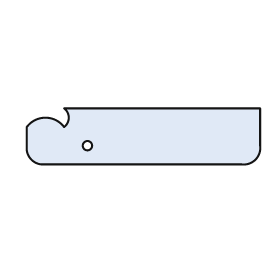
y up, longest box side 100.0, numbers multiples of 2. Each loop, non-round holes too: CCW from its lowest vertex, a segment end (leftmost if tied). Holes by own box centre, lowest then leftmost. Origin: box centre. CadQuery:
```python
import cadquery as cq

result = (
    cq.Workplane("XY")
    .moveTo(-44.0, -12.0)
    .lineTo(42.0, -12.0)
    .threePointArc((48.0, -10.0), (50.0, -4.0))
    .lineTo(50.0, 12.0)
    .lineTo(-34.0, 12.0)
    .threePointArc((-32.0, 8.0), (-34.0, 4.0))
    .threePointArc((-42.0, 8.0), (-50.0, 4.0))
    .lineTo(-50.0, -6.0)
    .threePointArc((-48.0, -10.0), (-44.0, -12.0))
    .close()
    .moveTo(-24.0, -4.0)
    .circle(2.0)
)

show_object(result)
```